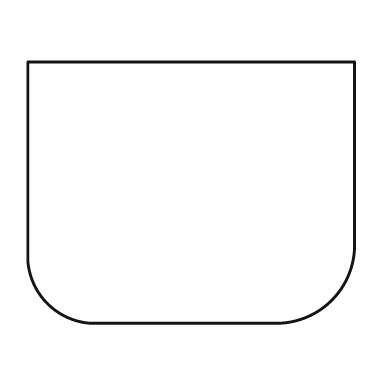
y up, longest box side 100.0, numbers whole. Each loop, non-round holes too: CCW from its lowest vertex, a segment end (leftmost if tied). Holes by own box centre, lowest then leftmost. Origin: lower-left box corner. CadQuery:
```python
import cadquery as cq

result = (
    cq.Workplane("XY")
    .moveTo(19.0, 0.0)
    .lineTo(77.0, 0.0)
    .threePointArc((93.0, 7.0), (100.0, 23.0))
    .lineTo(100.0, 80.0)
    .lineTo(0.0, 80.0)
    .lineTo(0.0, 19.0)
    .threePointArc((6.0, 6.0), (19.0, 0.0))
    .close()
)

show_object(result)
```